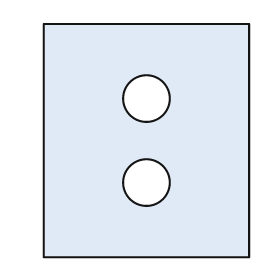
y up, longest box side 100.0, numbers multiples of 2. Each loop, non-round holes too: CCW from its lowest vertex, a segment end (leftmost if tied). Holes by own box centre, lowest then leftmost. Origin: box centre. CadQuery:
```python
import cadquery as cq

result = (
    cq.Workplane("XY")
    .moveTo(-44.0, -50.0)
    .lineTo(44.0, -50.0)
    .lineTo(44.0, 50.0)
    .lineTo(-44.0, 50.0)
    .close()
    .moveTo(0.0, -18.0)
    .circle(10.0)
    .moveTo(0.0, 18.0)
    .circle(10.0)
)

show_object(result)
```